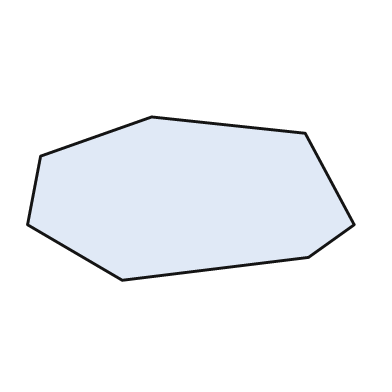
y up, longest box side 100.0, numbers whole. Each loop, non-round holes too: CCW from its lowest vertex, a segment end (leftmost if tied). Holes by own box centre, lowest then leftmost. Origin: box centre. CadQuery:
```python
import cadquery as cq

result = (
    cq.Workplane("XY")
    .moveTo(-21.0, -25.0)
    .lineTo(36.0, -18.0)
    .lineTo(50.0, -8.0)
    .lineTo(35.0, 20.0)
    .lineTo(-12.0, 25.0)
    .lineTo(-46.0, 13.0)
    .lineTo(-50.0, -8.0)
    .close()
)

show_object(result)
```